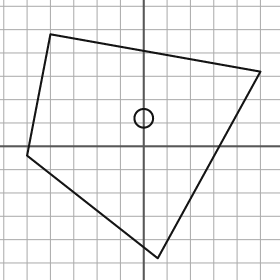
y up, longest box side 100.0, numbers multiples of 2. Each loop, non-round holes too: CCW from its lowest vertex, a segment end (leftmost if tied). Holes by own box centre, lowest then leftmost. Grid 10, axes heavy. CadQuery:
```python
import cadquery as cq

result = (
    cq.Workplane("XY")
    .moveTo(6.0, -48.0)
    .lineTo(50.0, 32.0)
    .lineTo(-40.0, 48.0)
    .lineTo(-50.0, -4.0)
    .close()
    .moveTo(0.0, 12.0)
    .circle(4.0)
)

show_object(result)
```